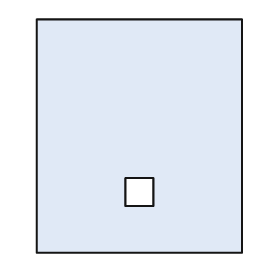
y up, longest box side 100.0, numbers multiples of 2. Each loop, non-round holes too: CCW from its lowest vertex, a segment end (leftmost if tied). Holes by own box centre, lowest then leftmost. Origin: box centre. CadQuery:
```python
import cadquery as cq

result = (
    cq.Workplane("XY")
    .moveTo(-44.0, -50.0)
    .lineTo(44.0, -50.0)
    .lineTo(44.0, 50.0)
    .lineTo(-44.0, 50.0)
    .close()
    .moveTo(-6.0, -30.0)
    .lineTo(6.0, -30.0)
    .lineTo(6.0, -18.0)
    .lineTo(-6.0, -18.0)
    .close()
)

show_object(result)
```